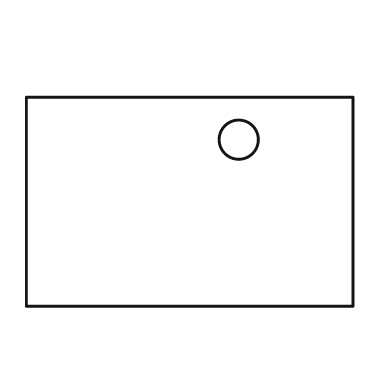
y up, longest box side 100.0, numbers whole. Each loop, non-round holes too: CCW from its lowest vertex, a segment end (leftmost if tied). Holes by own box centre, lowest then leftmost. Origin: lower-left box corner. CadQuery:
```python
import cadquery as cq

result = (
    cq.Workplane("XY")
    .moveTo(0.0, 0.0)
    .lineTo(100.0, 0.0)
    .lineTo(100.0, 64.0)
    .lineTo(0.0, 64.0)
    .close()
    .moveTo(65.0, 51.0)
    .circle(6.0)
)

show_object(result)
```